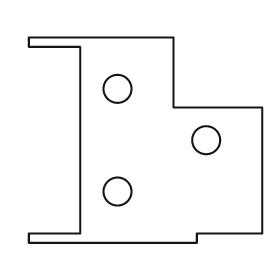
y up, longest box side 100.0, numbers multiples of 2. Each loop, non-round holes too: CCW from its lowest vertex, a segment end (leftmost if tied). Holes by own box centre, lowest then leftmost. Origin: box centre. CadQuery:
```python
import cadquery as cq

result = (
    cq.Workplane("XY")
    .moveTo(-50.0, -44.0)
    .lineTo(22.0, -44.0)
    .lineTo(22.0, -40.0)
    .lineTo(50.0, -40.0)
    .lineTo(50.0, 14.0)
    .lineTo(12.0, 14.0)
    .lineTo(12.0, 44.0)
    .lineTo(-50.0, 44.0)
    .lineTo(-50.0, 40.0)
    .lineTo(-28.0, 40.0)
    .lineTo(-28.0, -40.0)
    .lineTo(-50.0, -40.0)
    .close()
    .moveTo(-12.0, -22.0)
    .circle(6.0)
    .moveTo(26.0, 0.0)
    .circle(6.0)
    .moveTo(-12.0, 22.0)
    .circle(6.0)
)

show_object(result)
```